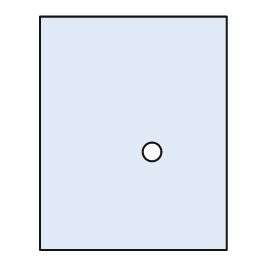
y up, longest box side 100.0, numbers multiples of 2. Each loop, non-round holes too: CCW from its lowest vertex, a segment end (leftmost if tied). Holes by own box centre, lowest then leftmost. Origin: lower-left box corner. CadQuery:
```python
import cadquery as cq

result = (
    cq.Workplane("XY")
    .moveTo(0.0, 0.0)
    .lineTo(80.0, 0.0)
    .lineTo(80.0, 100.0)
    .lineTo(0.0, 100.0)
    .close()
    .moveTo(48.0, 42.0)
    .circle(4.0)
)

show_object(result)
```